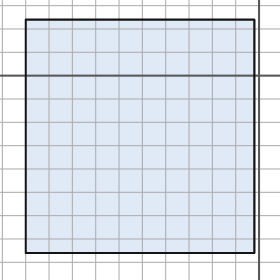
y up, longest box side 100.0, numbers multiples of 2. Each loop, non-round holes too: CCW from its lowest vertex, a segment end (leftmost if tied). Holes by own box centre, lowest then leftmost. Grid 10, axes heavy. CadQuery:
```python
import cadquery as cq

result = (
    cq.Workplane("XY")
    .moveTo(-100.0, -76.0)
    .lineTo(-2.0, -76.0)
    .lineTo(-2.0, 24.0)
    .lineTo(-100.0, 24.0)
    .close()
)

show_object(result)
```